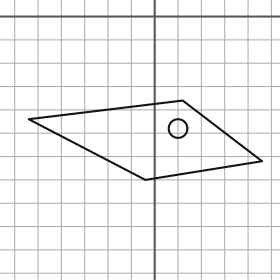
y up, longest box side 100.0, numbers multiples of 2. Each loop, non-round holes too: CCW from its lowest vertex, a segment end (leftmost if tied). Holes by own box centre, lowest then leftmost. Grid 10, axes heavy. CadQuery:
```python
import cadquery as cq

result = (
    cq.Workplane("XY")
    .moveTo(-4.0, -70.0)
    .lineTo(46.0, -62.0)
    .lineTo(12.0, -36.0)
    .lineTo(-54.0, -44.0)
    .close()
    .moveTo(10.0, -48.0)
    .circle(4.0)
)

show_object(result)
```